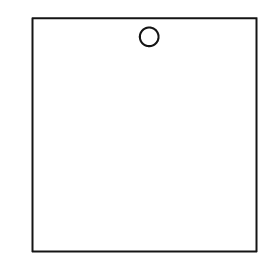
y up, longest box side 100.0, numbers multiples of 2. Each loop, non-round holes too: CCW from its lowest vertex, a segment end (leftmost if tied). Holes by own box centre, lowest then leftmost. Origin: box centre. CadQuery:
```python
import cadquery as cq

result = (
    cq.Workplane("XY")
    .moveTo(-48.0, -50.0)
    .lineTo(48.0, -50.0)
    .lineTo(48.0, 50.0)
    .lineTo(-48.0, 50.0)
    .close()
    .moveTo(2.0, 42.0)
    .circle(4.0)
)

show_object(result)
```